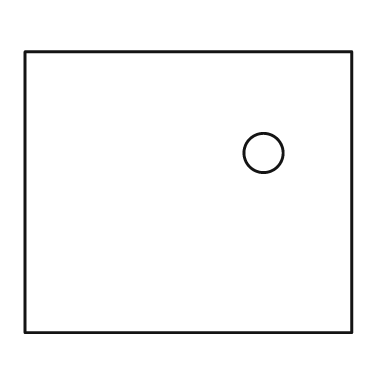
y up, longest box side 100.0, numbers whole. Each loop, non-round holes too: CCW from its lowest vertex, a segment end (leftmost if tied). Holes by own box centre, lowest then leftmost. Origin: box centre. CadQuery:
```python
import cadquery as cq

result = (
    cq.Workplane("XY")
    .moveTo(-50.0, -43.0)
    .lineTo(50.0, -43.0)
    .lineTo(50.0, 43.0)
    .lineTo(-50.0, 43.0)
    .close()
    .moveTo(23.0, 12.0)
    .circle(6.0)
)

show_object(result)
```